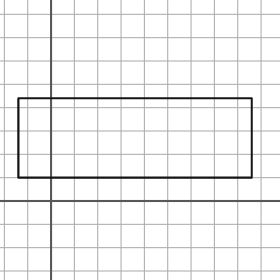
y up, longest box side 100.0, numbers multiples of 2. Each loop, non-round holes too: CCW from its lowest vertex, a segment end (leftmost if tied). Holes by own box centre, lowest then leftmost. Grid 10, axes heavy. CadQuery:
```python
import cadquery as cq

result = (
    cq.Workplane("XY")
    .moveTo(-14.0, 10.0)
    .lineTo(86.0, 10.0)
    .lineTo(86.0, 44.0)
    .lineTo(-14.0, 44.0)
    .close()
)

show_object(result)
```